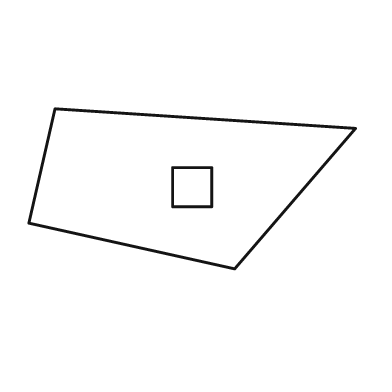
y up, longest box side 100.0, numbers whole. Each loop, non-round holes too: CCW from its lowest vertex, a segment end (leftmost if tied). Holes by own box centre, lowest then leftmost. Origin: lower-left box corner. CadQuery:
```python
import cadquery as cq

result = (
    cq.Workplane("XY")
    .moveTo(63.0, 0.0)
    .lineTo(100.0, 43.0)
    .lineTo(8.0, 49.0)
    .lineTo(0.0, 14.0)
    .close()
    .moveTo(44.0, 19.0)
    .lineTo(56.0, 19.0)
    .lineTo(56.0, 31.0)
    .lineTo(44.0, 31.0)
    .close()
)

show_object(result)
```